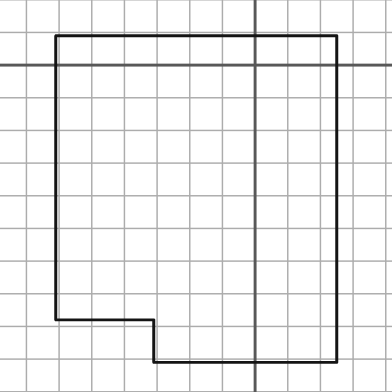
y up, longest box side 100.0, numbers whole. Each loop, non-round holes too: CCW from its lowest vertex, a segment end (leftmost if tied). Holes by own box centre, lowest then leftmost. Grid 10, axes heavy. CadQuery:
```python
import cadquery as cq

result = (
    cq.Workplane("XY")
    .moveTo(-31.0, -91.0)
    .lineTo(25.0, -91.0)
    .lineTo(25.0, 9.0)
    .lineTo(-61.0, 9.0)
    .lineTo(-61.0, -78.0)
    .lineTo(-31.0, -78.0)
    .close()
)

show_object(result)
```